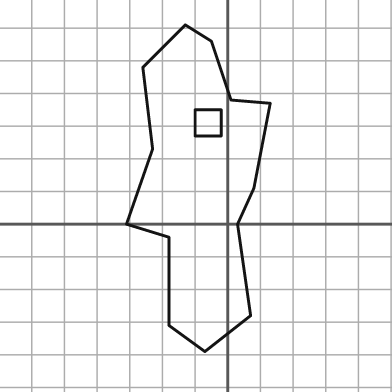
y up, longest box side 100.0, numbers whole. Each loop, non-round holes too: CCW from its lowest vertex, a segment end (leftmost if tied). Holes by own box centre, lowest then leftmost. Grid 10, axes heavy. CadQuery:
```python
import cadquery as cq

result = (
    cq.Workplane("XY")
    .moveTo(-7.0, -39.0)
    .lineTo(7.0, -28.0)
    .lineTo(3.0, 0.0)
    .lineTo(8.0, 11.0)
    .lineTo(13.0, 37.0)
    .lineTo(1.0, 38.0)
    .lineTo(-5.0, 56.0)
    .lineTo(-13.0, 61.0)
    .lineTo(-26.0, 48.0)
    .lineTo(-23.0, 23.0)
    .lineTo(-31.0, 0.0)
    .lineTo(-18.0, -4.0)
    .lineTo(-18.0, -31.0)
    .close()
    .moveTo(-10.0, 27.0)
    .lineTo(-2.0, 27.0)
    .lineTo(-2.0, 35.0)
    .lineTo(-10.0, 35.0)
    .close()
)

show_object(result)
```